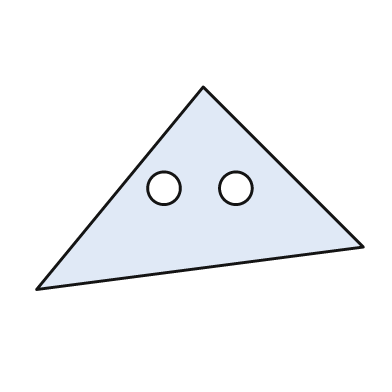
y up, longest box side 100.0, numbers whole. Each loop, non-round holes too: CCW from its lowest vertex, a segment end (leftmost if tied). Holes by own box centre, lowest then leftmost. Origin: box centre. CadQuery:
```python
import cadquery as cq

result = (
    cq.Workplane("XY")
    .moveTo(-50.0, -31.0)
    .lineTo(50.0, -18.0)
    .lineTo(1.0, 31.0)
    .close()
    .moveTo(-11.0, 0.0)
    .circle(5.0)
    .moveTo(11.0, 0.0)
    .circle(5.0)
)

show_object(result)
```